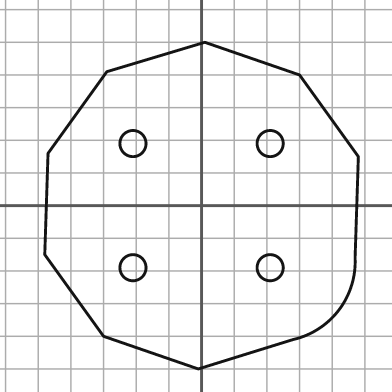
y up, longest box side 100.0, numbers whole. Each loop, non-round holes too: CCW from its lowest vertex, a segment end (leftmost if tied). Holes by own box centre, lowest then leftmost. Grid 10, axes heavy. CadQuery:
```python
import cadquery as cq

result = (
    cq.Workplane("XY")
    .moveTo(-1.0, -50.0)
    .lineTo(28.0, -41.0)
    .threePointArc((42.0, -32.0), (47.0, -16.0))
    .lineTo(48.0, 15.0)
    .lineTo(30.0, 40.0)
    .lineTo(1.0, 50.0)
    .lineTo(-29.0, 41.0)
    .lineTo(-47.0, 16.0)
    .lineTo(-48.0, -15.0)
    .lineTo(-30.0, -40.0)
    .close()
    .moveTo(-21.0, -19.0)
    .circle(4.0)
    .moveTo(21.0, -19.0)
    .circle(4.0)
    .moveTo(-21.0, 19.0)
    .circle(4.0)
    .moveTo(21.0, 19.0)
    .circle(4.0)
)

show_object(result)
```